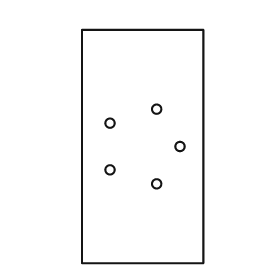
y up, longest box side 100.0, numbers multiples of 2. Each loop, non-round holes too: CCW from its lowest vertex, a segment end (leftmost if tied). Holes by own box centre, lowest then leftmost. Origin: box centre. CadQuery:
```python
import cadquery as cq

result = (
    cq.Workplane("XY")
    .moveTo(-26.0, -50.0)
    .lineTo(26.0, -50.0)
    .lineTo(26.0, 50.0)
    .lineTo(-26.0, 50.0)
    .close()
    .moveTo(6.0, -16.0)
    .circle(2.0)
    .moveTo(-14.0, -10.0)
    .circle(2.0)
    .moveTo(16.0, 0.0)
    .circle(2.0)
    .moveTo(-14.0, 10.0)
    .circle(2.0)
    .moveTo(6.0, 16.0)
    .circle(2.0)
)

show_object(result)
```